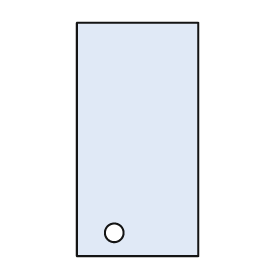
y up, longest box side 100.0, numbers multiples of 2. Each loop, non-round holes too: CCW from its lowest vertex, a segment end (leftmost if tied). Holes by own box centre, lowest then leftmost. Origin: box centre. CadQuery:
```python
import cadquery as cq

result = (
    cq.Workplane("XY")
    .moveTo(-26.0, -50.0)
    .lineTo(26.0, -50.0)
    .lineTo(26.0, 50.0)
    .lineTo(-26.0, 50.0)
    .close()
    .moveTo(-10.0, -40.0)
    .circle(4.0)
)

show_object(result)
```